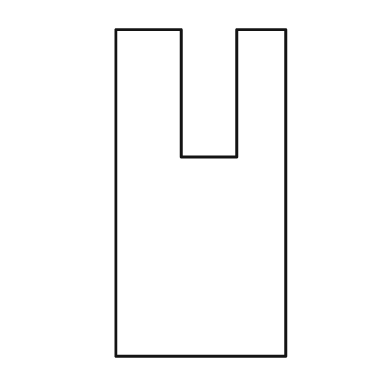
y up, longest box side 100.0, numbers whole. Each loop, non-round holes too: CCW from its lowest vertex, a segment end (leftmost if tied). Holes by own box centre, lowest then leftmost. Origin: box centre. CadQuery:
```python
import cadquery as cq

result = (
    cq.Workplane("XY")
    .moveTo(-26.0, -50.0)
    .lineTo(26.0, -50.0)
    .lineTo(26.0, 50.0)
    .lineTo(11.0, 50.0)
    .lineTo(11.0, 11.0)
    .lineTo(-6.0, 11.0)
    .lineTo(-6.0, 50.0)
    .lineTo(-26.0, 50.0)
    .close()
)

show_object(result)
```